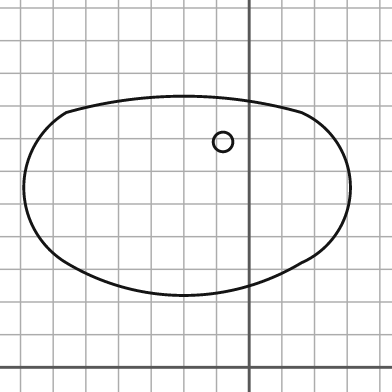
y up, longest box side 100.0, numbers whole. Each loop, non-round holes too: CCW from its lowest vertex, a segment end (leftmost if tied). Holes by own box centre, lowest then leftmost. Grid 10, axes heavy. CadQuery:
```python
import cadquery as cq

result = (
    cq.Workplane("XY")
    .moveTo(-56.0, 32.0)
    .threePointArc((-20.0, 22.0), (16.0, 32.0))
    .threePointArc((31.0, 55.0), (16.0, 78.0))
    .threePointArc((-20.0, 83.0), (-56.0, 78.0))
    .threePointArc((-69.0, 55.0), (-56.0, 32.0))
    .close()
    .moveTo(-8.0, 69.0)
    .circle(3.0)
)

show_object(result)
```